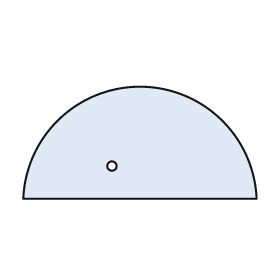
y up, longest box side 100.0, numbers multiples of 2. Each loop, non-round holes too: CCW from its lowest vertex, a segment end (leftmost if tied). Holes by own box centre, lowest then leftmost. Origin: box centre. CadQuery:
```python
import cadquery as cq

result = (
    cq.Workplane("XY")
    .moveTo(-50.0, -24.0)
    .lineTo(50.0, -24.0)
    .threePointArc((0.0, 24.0), (-50.0, -24.0))
    .close()
    .moveTo(-12.0, -10.0)
    .circle(2.0)
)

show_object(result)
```